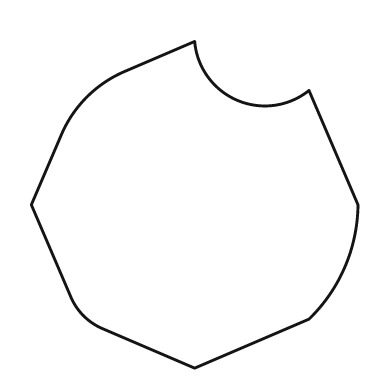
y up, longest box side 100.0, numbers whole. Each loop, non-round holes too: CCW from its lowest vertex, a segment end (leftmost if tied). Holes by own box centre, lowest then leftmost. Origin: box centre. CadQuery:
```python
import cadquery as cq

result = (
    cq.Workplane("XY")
    .moveTo(0.0, -50.0)
    .lineTo(35.0, -35.0)
    .threePointArc((46.0, -19.0), (50.0, 0.0))
    .lineTo(35.0, 35.0)
    .threePointArc((13.0, 32.0), (0.0, 50.0))
    .lineTo(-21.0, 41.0)
    .threePointArc((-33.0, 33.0), (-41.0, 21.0))
    .lineTo(-50.0, 0.0)
    .lineTo(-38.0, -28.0)
    .threePointArc((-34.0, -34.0), (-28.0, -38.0))
    .close()
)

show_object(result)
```